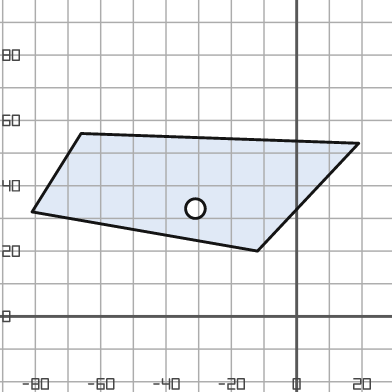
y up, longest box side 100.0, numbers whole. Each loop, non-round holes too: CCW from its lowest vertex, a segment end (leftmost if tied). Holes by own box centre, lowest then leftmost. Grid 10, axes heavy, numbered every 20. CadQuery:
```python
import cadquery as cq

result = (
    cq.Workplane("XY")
    .moveTo(-12.0, 20.0)
    .lineTo(19.0, 53.0)
    .lineTo(-66.0, 56.0)
    .lineTo(-81.0, 32.0)
    .close()
    .moveTo(-31.0, 33.0)
    .circle(3.0)
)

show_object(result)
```